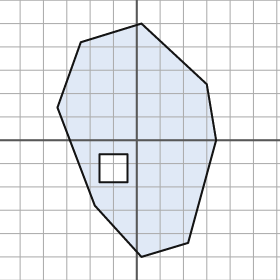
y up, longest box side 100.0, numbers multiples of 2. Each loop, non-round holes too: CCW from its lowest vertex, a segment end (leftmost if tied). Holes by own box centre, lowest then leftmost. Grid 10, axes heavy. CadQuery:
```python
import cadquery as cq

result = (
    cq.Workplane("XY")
    .moveTo(2.0, -50.0)
    .lineTo(22.0, -44.0)
    .lineTo(34.0, 0.0)
    .lineTo(30.0, 24.0)
    .lineTo(2.0, 50.0)
    .lineTo(-24.0, 42.0)
    .lineTo(-34.0, 14.0)
    .lineTo(-18.0, -28.0)
    .close()
    .moveTo(-16.0, -18.0)
    .lineTo(-4.0, -18.0)
    .lineTo(-4.0, -6.0)
    .lineTo(-16.0, -6.0)
    .close()
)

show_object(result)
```